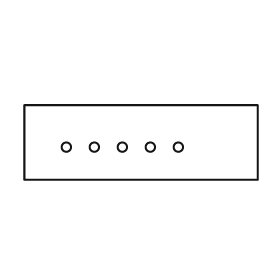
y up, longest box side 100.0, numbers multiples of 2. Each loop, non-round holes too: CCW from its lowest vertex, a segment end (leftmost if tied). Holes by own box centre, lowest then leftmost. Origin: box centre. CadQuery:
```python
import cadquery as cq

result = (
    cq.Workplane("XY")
    .moveTo(-50.0, -16.0)
    .lineTo(50.0, -16.0)
    .lineTo(50.0, 16.0)
    .lineTo(-50.0, 16.0)
    .close()
    .moveTo(-32.0, -2.0)
    .circle(2.0)
    .moveTo(-20.0, -2.0)
    .circle(2.0)
    .moveTo(-8.0, -2.0)
    .circle(2.0)
    .moveTo(4.0, -2.0)
    .circle(2.0)
    .moveTo(16.0, -2.0)
    .circle(2.0)
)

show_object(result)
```